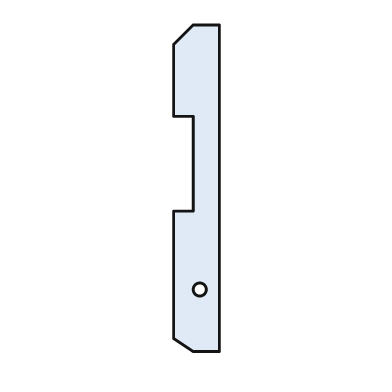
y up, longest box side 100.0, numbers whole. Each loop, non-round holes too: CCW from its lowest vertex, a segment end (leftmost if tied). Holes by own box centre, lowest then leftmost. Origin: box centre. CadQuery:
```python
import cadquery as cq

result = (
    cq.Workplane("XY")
    .moveTo(-1.0, -50.0)
    .lineTo(7.0, -50.0)
    .lineTo(7.0, 50.0)
    .lineTo(-1.0, 50.0)
    .lineTo(-7.0, 44.0)
    .lineTo(-7.0, 22.0)
    .lineTo(-1.0, 22.0)
    .lineTo(-1.0, -7.0)
    .lineTo(-7.0, -7.0)
    .lineTo(-7.0, -46.0)
    .close()
    .moveTo(1.0, -31.0)
    .circle(2.0)
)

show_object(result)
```